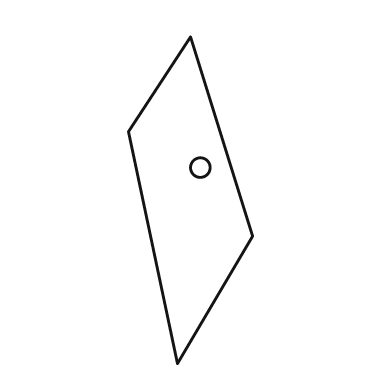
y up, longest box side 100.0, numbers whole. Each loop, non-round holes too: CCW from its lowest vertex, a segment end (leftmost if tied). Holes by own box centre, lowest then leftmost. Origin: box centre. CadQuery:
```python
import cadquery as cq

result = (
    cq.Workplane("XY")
    .moveTo(-4.0, -50.0)
    .lineTo(19.0, -11.0)
    .lineTo(0.0, 50.0)
    .lineTo(-19.0, 21.0)
    .close()
    .moveTo(3.0, 10.0)
    .circle(3.0)
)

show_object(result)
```